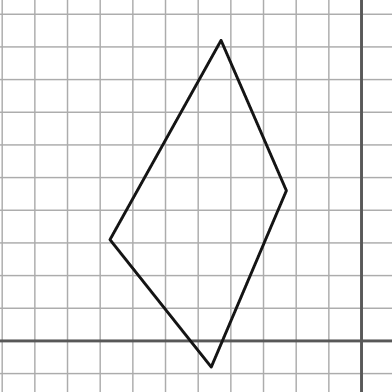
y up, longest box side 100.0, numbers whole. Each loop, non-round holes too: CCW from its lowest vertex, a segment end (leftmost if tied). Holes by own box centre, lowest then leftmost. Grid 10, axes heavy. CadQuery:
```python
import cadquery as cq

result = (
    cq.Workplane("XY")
    .moveTo(-46.0, -8.0)
    .lineTo(-23.0, 46.0)
    .lineTo(-43.0, 92.0)
    .lineTo(-77.0, 31.0)
    .close()
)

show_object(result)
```